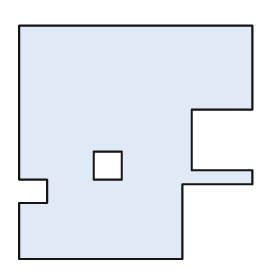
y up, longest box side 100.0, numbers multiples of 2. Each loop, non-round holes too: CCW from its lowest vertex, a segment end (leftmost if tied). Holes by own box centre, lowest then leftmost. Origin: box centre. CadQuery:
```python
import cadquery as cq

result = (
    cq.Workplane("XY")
    .moveTo(-50.0, -50.0)
    .lineTo(20.0, -50.0)
    .lineTo(20.0, -18.0)
    .lineTo(50.0, -18.0)
    .lineTo(50.0, -12.0)
    .lineTo(24.0, -12.0)
    .lineTo(24.0, 14.0)
    .lineTo(50.0, 14.0)
    .lineTo(50.0, 50.0)
    .lineTo(-50.0, 50.0)
    .lineTo(-50.0, -16.0)
    .lineTo(-38.0, -16.0)
    .lineTo(-38.0, -26.0)
    .lineTo(-50.0, -26.0)
    .close()
    .moveTo(-18.0, -16.0)
    .lineTo(-6.0, -16.0)
    .lineTo(-6.0, -4.0)
    .lineTo(-18.0, -4.0)
    .close()
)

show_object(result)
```